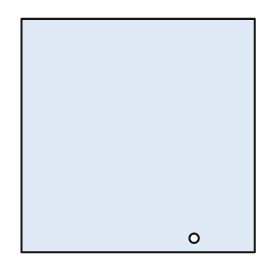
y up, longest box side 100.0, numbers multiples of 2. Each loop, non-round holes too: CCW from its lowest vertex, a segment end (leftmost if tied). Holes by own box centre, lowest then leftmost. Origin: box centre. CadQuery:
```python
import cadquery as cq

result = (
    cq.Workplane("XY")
    .moveTo(-50.0, -50.0)
    .lineTo(50.0, -50.0)
    .lineTo(50.0, 50.0)
    .lineTo(-50.0, 50.0)
    .close()
    .moveTo(24.0, -44.0)
    .circle(2.0)
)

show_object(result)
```